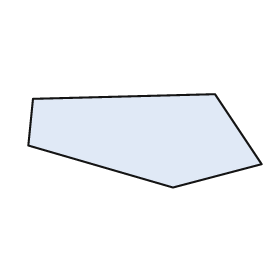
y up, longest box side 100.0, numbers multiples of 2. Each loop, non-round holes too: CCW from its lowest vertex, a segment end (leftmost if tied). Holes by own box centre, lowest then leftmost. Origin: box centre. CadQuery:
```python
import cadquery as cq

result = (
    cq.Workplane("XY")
    .moveTo(12.0, -20.0)
    .lineTo(50.0, -10.0)
    .lineTo(30.0, 20.0)
    .lineTo(-48.0, 18.0)
    .lineTo(-50.0, -2.0)
    .close()
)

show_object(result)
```